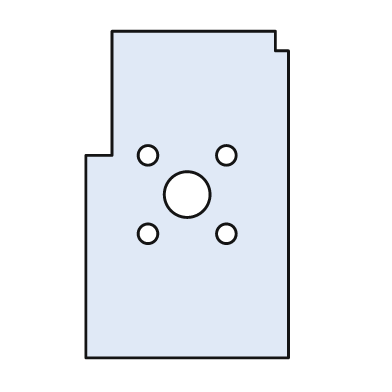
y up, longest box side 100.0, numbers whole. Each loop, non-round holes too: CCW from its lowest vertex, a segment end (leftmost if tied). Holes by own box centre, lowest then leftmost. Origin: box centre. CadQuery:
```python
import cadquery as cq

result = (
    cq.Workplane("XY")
    .moveTo(-31.0, -50.0)
    .lineTo(31.0, -50.0)
    .lineTo(31.0, 44.0)
    .lineTo(27.0, 44.0)
    .lineTo(27.0, 50.0)
    .lineTo(-23.0, 50.0)
    .lineTo(-23.0, 12.0)
    .lineTo(-31.0, 12.0)
    .close()
    .moveTo(-12.0, -12.0)
    .circle(3.0)
    .moveTo(12.0, -12.0)
    .circle(3.0)
    .moveTo(0.0, 0.0)
    .circle(7.0)
    .moveTo(-12.0, 12.0)
    .circle(3.0)
    .moveTo(12.0, 12.0)
    .circle(3.0)
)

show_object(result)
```